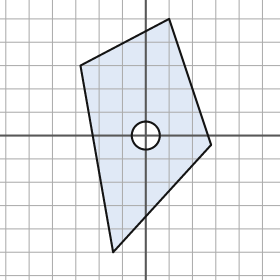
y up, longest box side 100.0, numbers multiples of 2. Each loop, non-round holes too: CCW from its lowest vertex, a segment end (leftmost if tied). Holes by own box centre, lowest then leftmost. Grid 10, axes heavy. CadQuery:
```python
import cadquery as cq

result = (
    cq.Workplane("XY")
    .moveTo(-14.0, -50.0)
    .lineTo(28.0, -4.0)
    .lineTo(10.0, 50.0)
    .lineTo(-28.0, 30.0)
    .close()
    .moveTo(0.0, 0.0)
    .circle(6.0)
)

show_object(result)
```